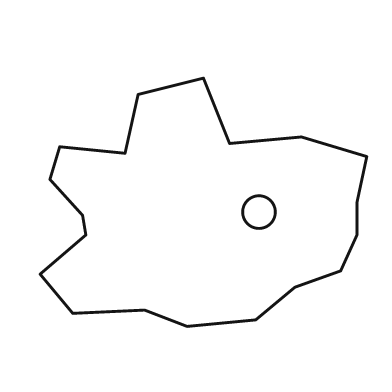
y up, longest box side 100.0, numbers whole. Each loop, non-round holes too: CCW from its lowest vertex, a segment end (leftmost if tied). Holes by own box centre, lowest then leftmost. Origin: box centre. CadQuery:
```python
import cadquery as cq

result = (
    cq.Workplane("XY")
    .moveTo(-5.0, -38.0)
    .lineTo(16.0, -36.0)
    .lineTo(28.0, -26.0)
    .lineTo(42.0, -21.0)
    .lineTo(47.0, -10.0)
    .lineTo(47.0, 0.0)
    .lineTo(50.0, 14.0)
    .lineTo(30.0, 20.0)
    .lineTo(8.0, 18.0)
    .lineTo(0.0, 38.0)
    .lineTo(-20.0, 33.0)
    .lineTo(-24.0, 15.0)
    .lineTo(-44.0, 17.0)
    .lineTo(-47.0, 7.0)
    .lineTo(-37.0, -4.0)
    .lineTo(-36.0, -10.0)
    .lineTo(-50.0, -22.0)
    .lineTo(-40.0, -34.0)
    .lineTo(-18.0, -33.0)
    .close()
    .moveTo(17.0, -3.0)
    .circle(5.0)
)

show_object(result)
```